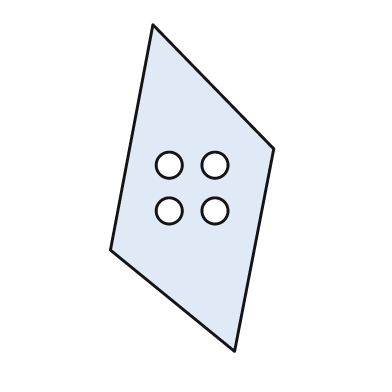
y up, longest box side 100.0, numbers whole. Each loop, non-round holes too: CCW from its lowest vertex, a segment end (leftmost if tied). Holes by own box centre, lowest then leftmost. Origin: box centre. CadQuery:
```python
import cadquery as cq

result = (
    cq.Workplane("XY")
    .moveTo(13.0, -50.0)
    .lineTo(25.0, 12.0)
    .lineTo(-12.0, 50.0)
    .lineTo(-25.0, -19.0)
    .close()
    .moveTo(-7.0, -7.0)
    .circle(4.0)
    .moveTo(7.0, -7.0)
    .circle(4.0)
    .moveTo(-7.0, 7.0)
    .circle(4.0)
    .moveTo(7.0, 7.0)
    .circle(4.0)
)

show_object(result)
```